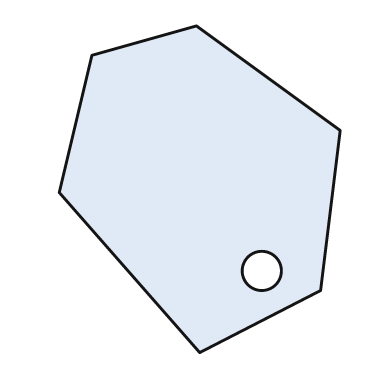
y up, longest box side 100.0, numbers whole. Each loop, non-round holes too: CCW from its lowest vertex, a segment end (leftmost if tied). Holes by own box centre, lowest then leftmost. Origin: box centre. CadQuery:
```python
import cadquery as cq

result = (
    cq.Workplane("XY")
    .moveTo(0.0, -50.0)
    .lineTo(37.0, -31.0)
    .lineTo(43.0, 18.0)
    .lineTo(-1.0, 50.0)
    .lineTo(-33.0, 41.0)
    .lineTo(-43.0, -1.0)
    .close()
    .moveTo(19.0, -25.0)
    .circle(6.0)
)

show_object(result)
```